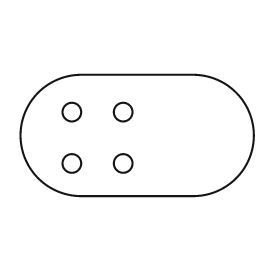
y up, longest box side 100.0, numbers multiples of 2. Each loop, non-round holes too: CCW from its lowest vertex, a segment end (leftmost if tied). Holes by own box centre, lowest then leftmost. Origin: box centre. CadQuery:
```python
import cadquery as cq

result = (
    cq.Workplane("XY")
    .moveTo(-24.0, -26.0)
    .lineTo(24.0, -26.0)
    .threePointArc((50.0, 0.0), (24.0, 26.0))
    .lineTo(-24.0, 26.0)
    .threePointArc((-50.0, 0.0), (-24.0, -26.0))
    .close()
    .moveTo(-28.0, -12.0)
    .circle(4.0)
    .moveTo(-6.0, -12.0)
    .circle(4.0)
    .moveTo(-28.0, 10.0)
    .circle(4.0)
    .moveTo(-6.0, 10.0)
    .circle(4.0)
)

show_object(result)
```